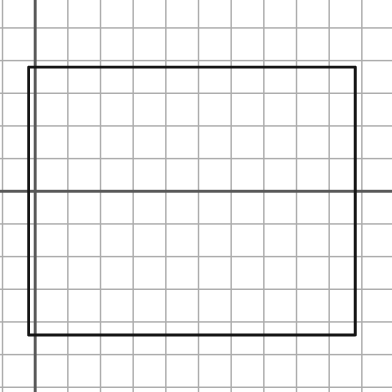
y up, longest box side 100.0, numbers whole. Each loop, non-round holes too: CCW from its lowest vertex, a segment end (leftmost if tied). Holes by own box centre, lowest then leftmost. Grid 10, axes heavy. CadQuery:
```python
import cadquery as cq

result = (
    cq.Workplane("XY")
    .moveTo(-2.0, -44.0)
    .lineTo(98.0, -44.0)
    .lineTo(98.0, 38.0)
    .lineTo(-2.0, 38.0)
    .close()
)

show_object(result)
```